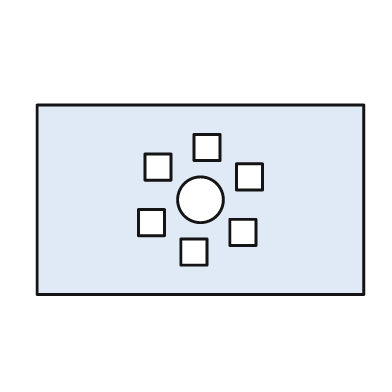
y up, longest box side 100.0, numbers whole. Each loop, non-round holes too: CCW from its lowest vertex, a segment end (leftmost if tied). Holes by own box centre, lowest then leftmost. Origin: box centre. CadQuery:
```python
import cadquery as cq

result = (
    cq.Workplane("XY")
    .moveTo(-50.0, -29.0)
    .lineTo(50.0, -29.0)
    .lineTo(50.0, 29.0)
    .lineTo(-50.0, 29.0)
    .close()
    .moveTo(-6.0, -20.0)
    .lineTo(2.0, -20.0)
    .lineTo(2.0, -12.0)
    .lineTo(-6.0, -12.0)
    .close()
    .moveTo(9.0, -14.0)
    .lineTo(17.0, -14.0)
    .lineTo(17.0, -6.0)
    .lineTo(9.0, -6.0)
    .close()
    .moveTo(-19.0, -11.0)
    .lineTo(-11.0, -11.0)
    .lineTo(-11.0, -3.0)
    .lineTo(-19.0, -3.0)
    .close()
    .moveTo(0.0, 0.0)
    .circle(7.0)
    .moveTo(11.0, 3.0)
    .lineTo(19.0, 3.0)
    .lineTo(19.0, 11.0)
    .lineTo(11.0, 11.0)
    .close()
    .moveTo(-17.0, 6.0)
    .lineTo(-9.0, 6.0)
    .lineTo(-9.0, 14.0)
    .lineTo(-17.0, 14.0)
    .close()
    .moveTo(-2.0, 12.0)
    .lineTo(6.0, 12.0)
    .lineTo(6.0, 20.0)
    .lineTo(-2.0, 20.0)
    .close()
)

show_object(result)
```